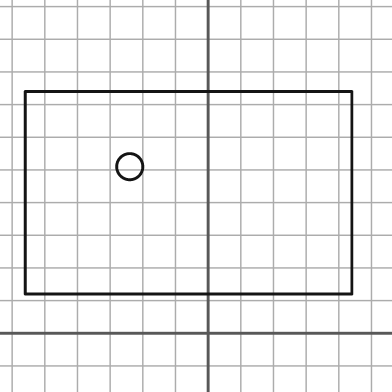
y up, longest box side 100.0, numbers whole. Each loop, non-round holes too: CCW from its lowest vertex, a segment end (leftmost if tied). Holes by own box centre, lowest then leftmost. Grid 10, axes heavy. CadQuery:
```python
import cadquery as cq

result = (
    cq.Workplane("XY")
    .moveTo(-56.0, 12.0)
    .lineTo(44.0, 12.0)
    .lineTo(44.0, 74.0)
    .lineTo(-56.0, 74.0)
    .close()
    .moveTo(-24.0, 51.0)
    .circle(4.0)
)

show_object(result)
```